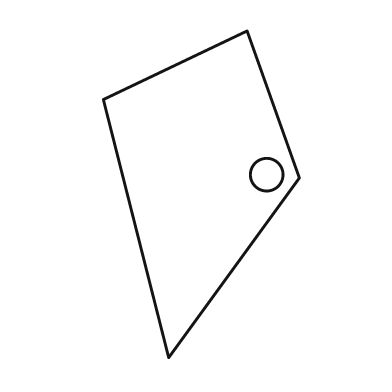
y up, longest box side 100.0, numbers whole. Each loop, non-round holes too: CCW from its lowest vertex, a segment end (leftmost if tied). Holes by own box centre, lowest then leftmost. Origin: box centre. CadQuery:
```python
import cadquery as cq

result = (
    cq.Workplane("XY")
    .moveTo(-10.0, -50.0)
    .lineTo(30.0, 5.0)
    .lineTo(14.0, 50.0)
    .lineTo(-30.0, 29.0)
    .close()
    .moveTo(20.0, 6.0)
    .circle(5.0)
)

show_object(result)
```